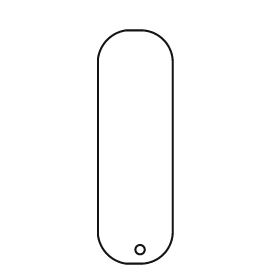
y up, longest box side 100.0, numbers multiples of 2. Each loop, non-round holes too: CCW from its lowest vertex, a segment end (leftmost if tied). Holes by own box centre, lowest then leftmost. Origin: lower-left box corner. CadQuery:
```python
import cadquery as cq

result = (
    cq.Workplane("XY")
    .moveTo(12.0, 0.0)
    .lineTo(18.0, 0.0)
    .threePointArc((28.0, 4.0), (32.0, 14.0))
    .lineTo(32.0, 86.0)
    .threePointArc((28.0, 96.0), (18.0, 100.0))
    .lineTo(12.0, 100.0)
    .threePointArc((4.0, 96.0), (0.0, 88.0))
    .lineTo(0.0, 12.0)
    .threePointArc((4.0, 4.0), (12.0, 0.0))
    .close()
    .moveTo(18.0, 6.0)
    .circle(2.0)
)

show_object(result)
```